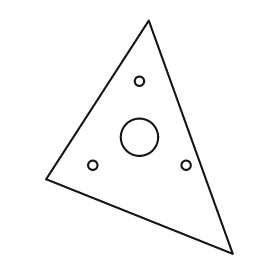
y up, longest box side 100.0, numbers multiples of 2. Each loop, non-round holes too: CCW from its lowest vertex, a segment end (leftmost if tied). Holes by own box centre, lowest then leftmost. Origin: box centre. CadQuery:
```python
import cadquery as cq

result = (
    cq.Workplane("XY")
    .moveTo(40.0, -50.0)
    .lineTo(4.0, 50.0)
    .lineTo(-40.0, -18.0)
    .close()
    .moveTo(-20.0, -12.0)
    .circle(2.0)
    .moveTo(20.0, -12.0)
    .circle(2.0)
    .moveTo(0.0, 0.0)
    .circle(8.0)
    .moveTo(0.0, 24.0)
    .circle(2.0)
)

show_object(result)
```